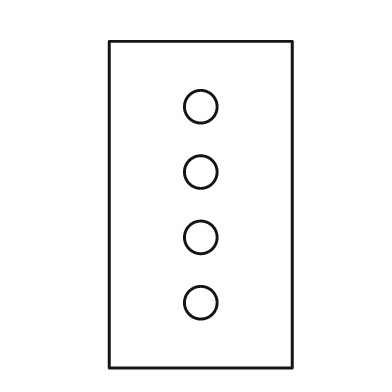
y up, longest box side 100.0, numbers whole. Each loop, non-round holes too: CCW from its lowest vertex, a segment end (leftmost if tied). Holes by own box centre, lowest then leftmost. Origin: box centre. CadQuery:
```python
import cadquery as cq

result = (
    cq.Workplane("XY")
    .moveTo(-28.0, -50.0)
    .lineTo(28.0, -50.0)
    .lineTo(28.0, 50.0)
    .lineTo(-28.0, 50.0)
    .close()
    .moveTo(0.0, -30.0)
    .circle(5.0)
    .moveTo(0.0, -10.0)
    .circle(5.0)
    .moveTo(0.0, 10.0)
    .circle(5.0)
    .moveTo(0.0, 30.0)
    .circle(5.0)
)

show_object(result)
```